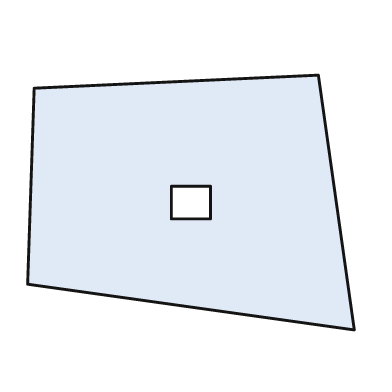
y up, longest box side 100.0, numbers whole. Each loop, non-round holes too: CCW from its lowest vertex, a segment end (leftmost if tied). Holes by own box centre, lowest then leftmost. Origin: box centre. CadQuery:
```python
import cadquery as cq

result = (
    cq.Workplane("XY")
    .moveTo(50.0, -39.0)
    .lineTo(39.0, 39.0)
    .lineTo(-48.0, 35.0)
    .lineTo(-50.0, -25.0)
    .close()
    .moveTo(-6.0, -5.0)
    .lineTo(6.0, -5.0)
    .lineTo(6.0, 5.0)
    .lineTo(-6.0, 5.0)
    .close()
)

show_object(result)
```